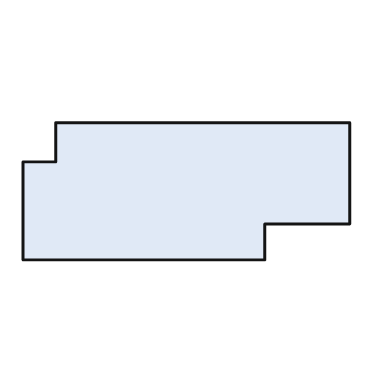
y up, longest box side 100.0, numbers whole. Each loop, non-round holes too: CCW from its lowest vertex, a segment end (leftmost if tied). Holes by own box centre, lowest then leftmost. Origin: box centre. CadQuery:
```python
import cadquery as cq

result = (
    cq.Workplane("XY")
    .moveTo(-50.0, -21.0)
    .lineTo(24.0, -21.0)
    .lineTo(24.0, -10.0)
    .lineTo(50.0, -10.0)
    .lineTo(50.0, 21.0)
    .lineTo(-40.0, 21.0)
    .lineTo(-40.0, 9.0)
    .lineTo(-50.0, 9.0)
    .close()
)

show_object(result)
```